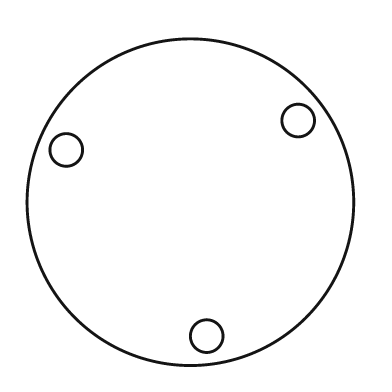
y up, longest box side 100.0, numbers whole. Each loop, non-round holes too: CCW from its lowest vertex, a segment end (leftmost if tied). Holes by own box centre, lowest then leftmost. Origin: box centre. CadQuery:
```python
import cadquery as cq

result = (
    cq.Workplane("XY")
    .moveTo(0.0, 0.0)
    .circle(50.0)
    .moveTo(5.0, -41.0)
    .circle(5.0)
    .moveTo(-38.0, 16.0)
    .circle(5.0)
    .moveTo(33.0, 25.0)
    .circle(5.0)
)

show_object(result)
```